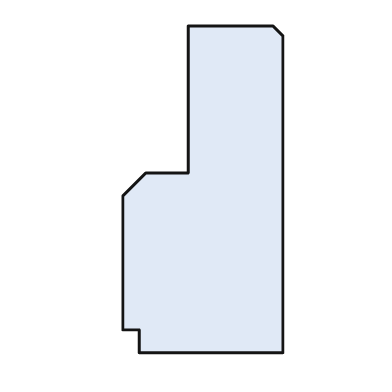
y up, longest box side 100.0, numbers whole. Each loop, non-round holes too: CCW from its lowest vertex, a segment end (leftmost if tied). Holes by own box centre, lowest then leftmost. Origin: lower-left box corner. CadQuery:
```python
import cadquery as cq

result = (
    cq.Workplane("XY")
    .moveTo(5.0, 0.0)
    .lineTo(49.0, 0.0)
    .lineTo(49.0, 97.0)
    .lineTo(46.0, 100.0)
    .lineTo(20.0, 100.0)
    .lineTo(20.0, 55.0)
    .lineTo(7.0, 55.0)
    .lineTo(0.0, 48.0)
    .lineTo(0.0, 7.0)
    .lineTo(5.0, 7.0)
    .close()
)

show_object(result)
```